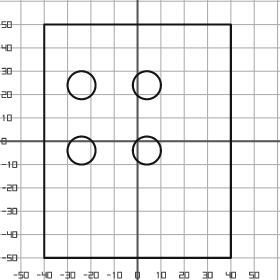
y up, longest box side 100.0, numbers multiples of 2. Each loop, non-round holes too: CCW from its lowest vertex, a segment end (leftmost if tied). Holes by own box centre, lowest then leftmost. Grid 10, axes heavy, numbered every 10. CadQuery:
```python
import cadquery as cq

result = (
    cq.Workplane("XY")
    .moveTo(-40.0, -50.0)
    .lineTo(40.0, -50.0)
    .lineTo(40.0, 50.0)
    .lineTo(-40.0, 50.0)
    .close()
    .moveTo(-24.0, -4.0)
    .circle(6.0)
    .moveTo(4.0, -4.0)
    .circle(6.0)
    .moveTo(-24.0, 24.0)
    .circle(6.0)
    .moveTo(4.0, 24.0)
    .circle(6.0)
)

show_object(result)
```